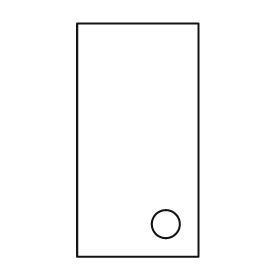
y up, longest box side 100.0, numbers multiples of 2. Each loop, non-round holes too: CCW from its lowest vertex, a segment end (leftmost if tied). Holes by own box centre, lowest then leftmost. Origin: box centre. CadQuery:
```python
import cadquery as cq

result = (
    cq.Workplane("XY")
    .moveTo(-26.0, -50.0)
    .lineTo(26.0, -50.0)
    .lineTo(26.0, 50.0)
    .lineTo(-26.0, 50.0)
    .close()
    .moveTo(12.0, -36.0)
    .circle(6.0)
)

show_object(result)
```